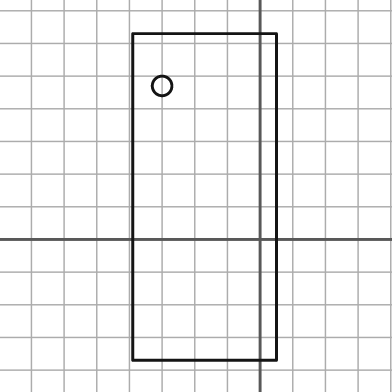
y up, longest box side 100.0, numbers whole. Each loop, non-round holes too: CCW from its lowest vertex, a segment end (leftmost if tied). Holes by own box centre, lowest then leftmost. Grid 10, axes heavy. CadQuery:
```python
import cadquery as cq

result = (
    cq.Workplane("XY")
    .moveTo(-39.0, -37.0)
    .lineTo(5.0, -37.0)
    .lineTo(5.0, 63.0)
    .lineTo(-39.0, 63.0)
    .close()
    .moveTo(-30.0, 47.0)
    .circle(3.0)
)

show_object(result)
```